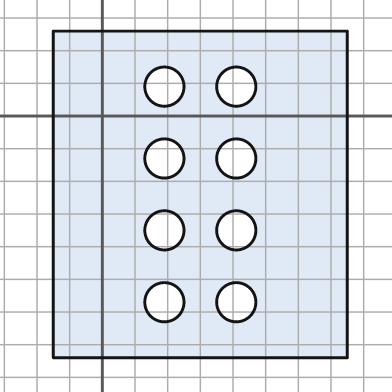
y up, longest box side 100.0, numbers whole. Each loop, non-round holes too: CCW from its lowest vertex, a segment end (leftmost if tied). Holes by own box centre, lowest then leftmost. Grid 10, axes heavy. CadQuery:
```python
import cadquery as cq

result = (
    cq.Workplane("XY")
    .moveTo(-15.0, -74.0)
    .lineTo(75.0, -74.0)
    .lineTo(75.0, 26.0)
    .lineTo(-15.0, 26.0)
    .close()
    .moveTo(19.0, -57.0)
    .circle(6.0)
    .moveTo(41.0, -57.0)
    .circle(6.0)
    .moveTo(19.0, -35.0)
    .circle(6.0)
    .moveTo(41.0, -35.0)
    .circle(6.0)
    .moveTo(19.0, -13.0)
    .circle(6.0)
    .moveTo(41.0, -13.0)
    .circle(6.0)
    .moveTo(19.0, 9.0)
    .circle(6.0)
    .moveTo(41.0, 9.0)
    .circle(6.0)
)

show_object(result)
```